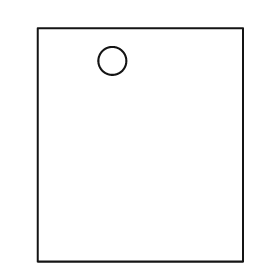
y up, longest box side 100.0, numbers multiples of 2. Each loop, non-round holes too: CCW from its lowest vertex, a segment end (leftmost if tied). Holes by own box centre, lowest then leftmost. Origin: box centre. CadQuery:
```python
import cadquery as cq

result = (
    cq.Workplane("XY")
    .moveTo(-44.0, -50.0)
    .lineTo(44.0, -50.0)
    .lineTo(44.0, 50.0)
    .lineTo(-44.0, 50.0)
    .close()
    .moveTo(-12.0, 36.0)
    .circle(6.0)
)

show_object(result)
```